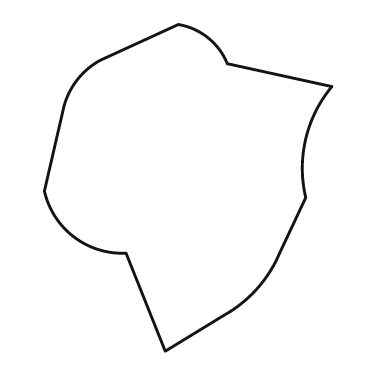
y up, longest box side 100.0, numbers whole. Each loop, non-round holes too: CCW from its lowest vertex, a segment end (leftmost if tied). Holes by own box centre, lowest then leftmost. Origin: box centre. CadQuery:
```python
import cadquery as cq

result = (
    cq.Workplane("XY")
    .moveTo(-7.0, -50.0)
    .lineTo(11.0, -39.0)
    .threePointArc((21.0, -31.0), (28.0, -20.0))
    .lineTo(36.0, -3.0)
    .threePointArc((36.0, 15.0), (44.0, 31.0))
    .lineTo(12.0, 38.0)
    .threePointArc((6.0, 46.0), (-3.0, 50.0))
    .lineTo(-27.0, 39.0)
    .threePointArc((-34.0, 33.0), (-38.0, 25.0))
    .lineTo(-44.0, -1.0)
    .threePointArc((-35.0, -15.0), (-19.0, -20.0))
    .close()
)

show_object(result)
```